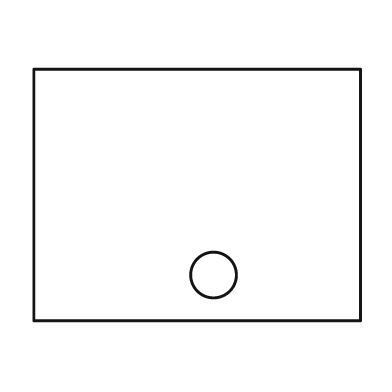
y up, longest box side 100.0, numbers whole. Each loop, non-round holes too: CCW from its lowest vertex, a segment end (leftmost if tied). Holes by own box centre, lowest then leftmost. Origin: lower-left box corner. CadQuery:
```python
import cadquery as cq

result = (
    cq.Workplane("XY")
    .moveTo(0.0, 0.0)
    .lineTo(100.0, 0.0)
    .lineTo(100.0, 77.0)
    .lineTo(0.0, 77.0)
    .close()
    .moveTo(55.0, 14.0)
    .circle(7.0)
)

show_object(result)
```